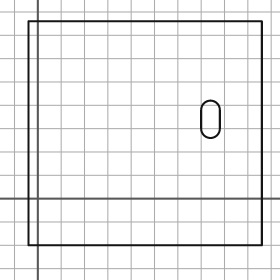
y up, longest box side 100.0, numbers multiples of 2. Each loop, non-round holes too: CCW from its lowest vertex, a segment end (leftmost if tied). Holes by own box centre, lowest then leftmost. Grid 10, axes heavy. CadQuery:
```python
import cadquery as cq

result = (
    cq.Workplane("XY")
    .moveTo(-4.0, -20.0)
    .lineTo(96.0, -20.0)
    .lineTo(96.0, 76.0)
    .lineTo(-4.0, 76.0)
    .close()
    .moveTo(70.0, 30.0)
    .threePointArc((74.0, 26.0), (78.0, 30.0))
    .lineTo(78.0, 38.0)
    .threePointArc((74.0, 42.0), (70.0, 38.0))
    .close()
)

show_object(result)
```